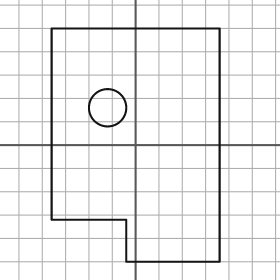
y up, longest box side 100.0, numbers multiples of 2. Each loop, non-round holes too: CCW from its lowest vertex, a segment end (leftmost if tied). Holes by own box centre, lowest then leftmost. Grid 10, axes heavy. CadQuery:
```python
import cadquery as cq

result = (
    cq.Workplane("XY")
    .moveTo(-4.0, -50.0)
    .lineTo(36.0, -50.0)
    .lineTo(36.0, 50.0)
    .lineTo(-36.0, 50.0)
    .lineTo(-36.0, -32.0)
    .lineTo(-4.0, -32.0)
    .close()
    .moveTo(-12.0, 16.0)
    .circle(8.0)
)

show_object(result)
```